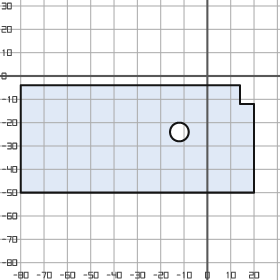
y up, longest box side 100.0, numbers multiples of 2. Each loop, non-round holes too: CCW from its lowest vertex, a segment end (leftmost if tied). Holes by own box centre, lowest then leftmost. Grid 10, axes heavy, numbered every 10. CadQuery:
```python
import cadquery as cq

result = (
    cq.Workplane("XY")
    .moveTo(-80.0, -50.0)
    .lineTo(20.0, -50.0)
    .lineTo(20.0, -12.0)
    .lineTo(14.0, -12.0)
    .lineTo(14.0, -4.0)
    .lineTo(-80.0, -4.0)
    .close()
    .moveTo(-12.0, -24.0)
    .circle(4.0)
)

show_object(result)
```